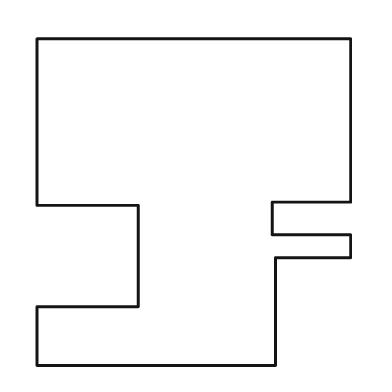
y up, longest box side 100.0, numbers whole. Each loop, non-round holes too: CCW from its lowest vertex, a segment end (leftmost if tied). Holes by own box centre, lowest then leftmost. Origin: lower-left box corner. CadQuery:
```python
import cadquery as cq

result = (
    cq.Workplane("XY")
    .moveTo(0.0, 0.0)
    .lineTo(73.0, 0.0)
    .lineTo(73.0, 33.0)
    .lineTo(96.0, 33.0)
    .lineTo(96.0, 40.0)
    .lineTo(72.0, 40.0)
    .lineTo(72.0, 50.0)
    .lineTo(96.0, 50.0)
    .lineTo(96.0, 100.0)
    .lineTo(0.0, 100.0)
    .lineTo(0.0, 49.0)
    .lineTo(31.0, 49.0)
    .lineTo(31.0, 18.0)
    .lineTo(0.0, 18.0)
    .close()
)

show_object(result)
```